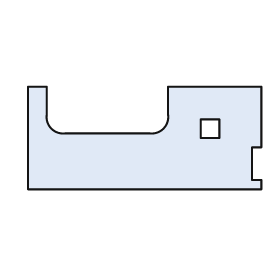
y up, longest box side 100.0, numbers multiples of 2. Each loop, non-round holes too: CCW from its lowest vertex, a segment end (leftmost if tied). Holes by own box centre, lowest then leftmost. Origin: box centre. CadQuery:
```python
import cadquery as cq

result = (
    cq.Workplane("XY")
    .moveTo(-50.0, -22.0)
    .lineTo(50.0, -22.0)
    .lineTo(50.0, -18.0)
    .lineTo(46.0, -18.0)
    .lineTo(46.0, -4.0)
    .lineTo(50.0, -4.0)
    .lineTo(50.0, 22.0)
    .lineTo(10.0, 22.0)
    .lineTo(10.0, 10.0)
    .threePointArc((8.0, 4.0), (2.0, 2.0))
    .lineTo(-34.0, 2.0)
    .threePointArc((-40.0, 4.0), (-42.0, 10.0))
    .lineTo(-42.0, 22.0)
    .lineTo(-50.0, 22.0)
    .close()
    .moveTo(24.0, 0.0)
    .lineTo(32.0, 0.0)
    .lineTo(32.0, 8.0)
    .lineTo(24.0, 8.0)
    .close()
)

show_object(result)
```